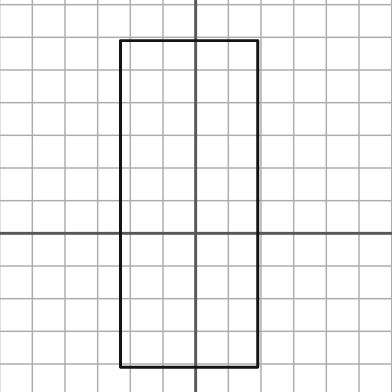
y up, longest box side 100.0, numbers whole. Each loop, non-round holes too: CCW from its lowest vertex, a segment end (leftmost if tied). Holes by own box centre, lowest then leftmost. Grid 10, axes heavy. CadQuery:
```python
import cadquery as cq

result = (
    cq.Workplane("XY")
    .moveTo(-23.0, -41.0)
    .lineTo(19.0, -41.0)
    .lineTo(19.0, 59.0)
    .lineTo(-23.0, 59.0)
    .close()
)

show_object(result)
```